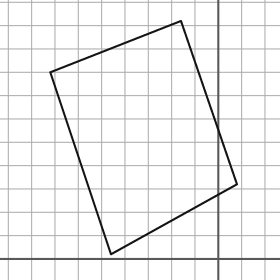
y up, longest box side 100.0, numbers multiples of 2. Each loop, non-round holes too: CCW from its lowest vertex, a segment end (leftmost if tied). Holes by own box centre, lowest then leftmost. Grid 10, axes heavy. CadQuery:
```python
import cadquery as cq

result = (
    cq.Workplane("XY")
    .moveTo(-46.0, 2.0)
    .lineTo(8.0, 32.0)
    .lineTo(-16.0, 102.0)
    .lineTo(-72.0, 80.0)
    .close()
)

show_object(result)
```